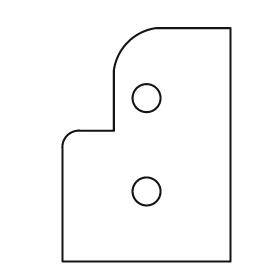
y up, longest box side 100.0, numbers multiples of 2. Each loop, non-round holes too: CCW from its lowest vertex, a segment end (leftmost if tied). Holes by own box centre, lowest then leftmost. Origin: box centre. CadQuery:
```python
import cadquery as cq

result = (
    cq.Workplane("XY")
    .moveTo(-36.0, -50.0)
    .lineTo(36.0, -50.0)
    .lineTo(36.0, 50.0)
    .lineTo(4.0, 50.0)
    .threePointArc((-8.0, 44.0), (-14.0, 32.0))
    .lineTo(-14.0, 6.0)
    .lineTo(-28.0, 6.0)
    .threePointArc((-34.0, 4.0), (-36.0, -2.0))
    .close()
    .moveTo(0.0, -20.0)
    .circle(6.0)
    .moveTo(0.0, 20.0)
    .circle(6.0)
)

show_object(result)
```